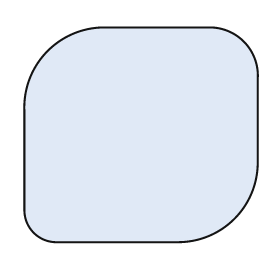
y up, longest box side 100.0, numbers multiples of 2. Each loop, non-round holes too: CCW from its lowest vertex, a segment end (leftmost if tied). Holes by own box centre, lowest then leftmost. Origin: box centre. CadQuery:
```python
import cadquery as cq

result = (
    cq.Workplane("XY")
    .moveTo(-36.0, -46.0)
    .lineTo(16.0, -46.0)
    .threePointArc((40.0, -36.0), (50.0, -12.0))
    .lineTo(50.0, 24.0)
    .threePointArc((44.0, 40.0), (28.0, 46.0))
    .lineTo(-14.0, 46.0)
    .threePointArc((-40.0, 36.0), (-50.0, 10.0))
    .lineTo(-50.0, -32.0)
    .threePointArc((-46.0, -42.0), (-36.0, -46.0))
    .close()
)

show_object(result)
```